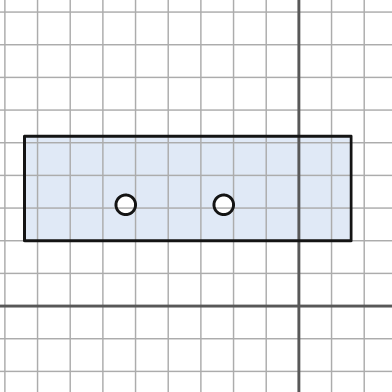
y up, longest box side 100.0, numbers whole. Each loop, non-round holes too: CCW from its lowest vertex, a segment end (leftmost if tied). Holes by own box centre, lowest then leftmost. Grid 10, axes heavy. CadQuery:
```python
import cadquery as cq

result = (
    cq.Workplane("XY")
    .moveTo(-84.0, 20.0)
    .lineTo(16.0, 20.0)
    .lineTo(16.0, 52.0)
    .lineTo(-84.0, 52.0)
    .close()
    .moveTo(-53.0, 31.0)
    .circle(3.0)
    .moveTo(-23.0, 31.0)
    .circle(3.0)
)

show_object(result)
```